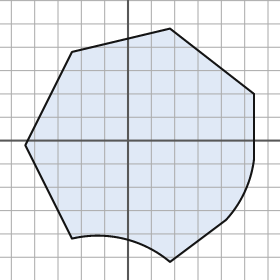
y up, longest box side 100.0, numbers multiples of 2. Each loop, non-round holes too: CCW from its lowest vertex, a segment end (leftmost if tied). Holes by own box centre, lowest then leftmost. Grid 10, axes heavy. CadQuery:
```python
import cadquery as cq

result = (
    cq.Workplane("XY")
    .moveTo(18.0, -52.0)
    .lineTo(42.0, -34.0)
    .threePointArc((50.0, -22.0), (54.0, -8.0))
    .lineTo(54.0, 20.0)
    .lineTo(18.0, 48.0)
    .lineTo(-24.0, 38.0)
    .lineTo(-44.0, -2.0)
    .lineTo(-24.0, -42.0)
    .threePointArc((-2.0, -42.0), (18.0, -52.0))
    .close()
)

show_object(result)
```